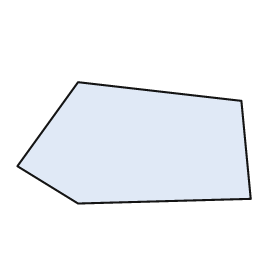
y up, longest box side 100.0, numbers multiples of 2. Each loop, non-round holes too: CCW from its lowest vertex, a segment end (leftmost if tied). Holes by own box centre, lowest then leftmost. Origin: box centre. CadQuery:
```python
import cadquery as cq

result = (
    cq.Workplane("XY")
    .moveTo(-24.0, -26.0)
    .lineTo(50.0, -24.0)
    .lineTo(46.0, 18.0)
    .lineTo(-24.0, 26.0)
    .lineTo(-50.0, -10.0)
    .close()
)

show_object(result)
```